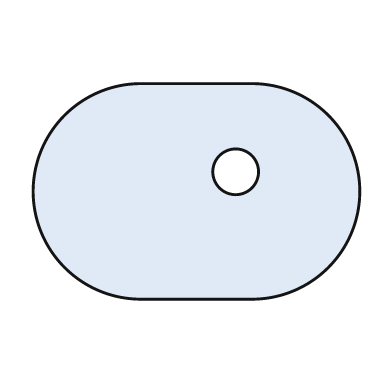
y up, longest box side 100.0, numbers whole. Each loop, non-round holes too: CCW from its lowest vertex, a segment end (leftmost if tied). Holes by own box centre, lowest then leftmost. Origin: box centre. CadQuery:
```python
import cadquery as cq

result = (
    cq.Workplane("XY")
    .moveTo(-17.0, -33.0)
    .lineTo(17.0, -33.0)
    .threePointArc((50.0, 0.0), (17.0, 33.0))
    .lineTo(-17.0, 33.0)
    .threePointArc((-50.0, 0.0), (-17.0, -33.0))
    .close()
    .moveTo(12.0, 6.0)
    .circle(7.0)
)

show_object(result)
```